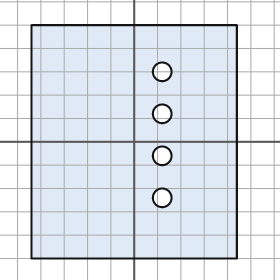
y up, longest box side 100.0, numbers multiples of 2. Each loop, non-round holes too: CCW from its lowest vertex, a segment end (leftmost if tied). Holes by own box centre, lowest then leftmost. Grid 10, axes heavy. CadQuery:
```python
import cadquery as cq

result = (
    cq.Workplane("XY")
    .moveTo(-44.0, -50.0)
    .lineTo(44.0, -50.0)
    .lineTo(44.0, 50.0)
    .lineTo(-44.0, 50.0)
    .close()
    .moveTo(12.0, -24.0)
    .circle(4.0)
    .moveTo(12.0, -6.0)
    .circle(4.0)
    .moveTo(12.0, 12.0)
    .circle(4.0)
    .moveTo(12.0, 30.0)
    .circle(4.0)
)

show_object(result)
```